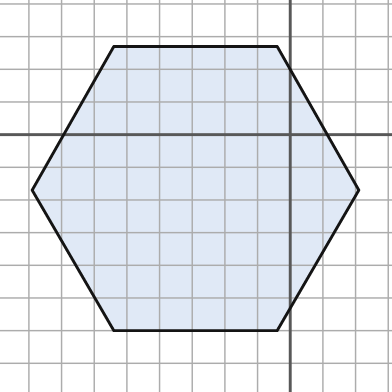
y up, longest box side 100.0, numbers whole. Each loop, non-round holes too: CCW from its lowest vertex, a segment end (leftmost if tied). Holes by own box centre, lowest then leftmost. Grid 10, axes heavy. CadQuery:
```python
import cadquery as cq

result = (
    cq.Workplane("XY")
    .moveTo(-54.0, -60.0)
    .lineTo(-4.0, -60.0)
    .lineTo(21.0, -17.0)
    .lineTo(-4.0, 27.0)
    .lineTo(-54.0, 27.0)
    .lineTo(-79.0, -17.0)
    .close()
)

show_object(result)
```